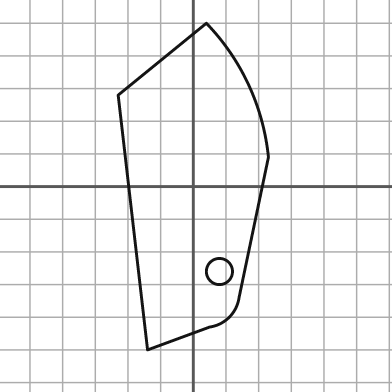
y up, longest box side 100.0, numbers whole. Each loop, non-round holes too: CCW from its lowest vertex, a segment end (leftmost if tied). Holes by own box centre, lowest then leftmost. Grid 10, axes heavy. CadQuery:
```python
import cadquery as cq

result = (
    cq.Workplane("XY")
    .moveTo(-14.0, -50.0)
    .lineTo(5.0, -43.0)
    .threePointArc((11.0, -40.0), (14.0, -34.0))
    .lineTo(23.0, 9.0)
    .threePointArc((17.0, 31.0), (4.0, 50.0))
    .lineTo(-23.0, 28.0)
    .close()
    .moveTo(8.0, -26.0)
    .circle(4.0)
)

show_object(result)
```